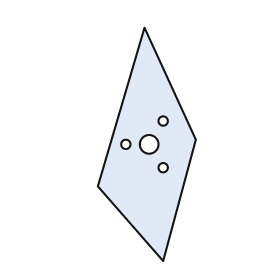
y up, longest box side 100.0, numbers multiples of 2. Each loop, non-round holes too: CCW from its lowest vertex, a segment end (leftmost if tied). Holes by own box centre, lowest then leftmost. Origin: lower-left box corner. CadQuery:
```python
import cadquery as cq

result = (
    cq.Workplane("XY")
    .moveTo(28.0, 0.0)
    .lineTo(42.0, 52.0)
    .lineTo(20.0, 100.0)
    .lineTo(0.0, 32.0)
    .close()
    .moveTo(28.0, 40.0)
    .circle(2.0)
    .moveTo(12.0, 50.0)
    .circle(2.0)
    .moveTo(22.0, 50.0)
    .circle(4.0)
    .moveTo(28.0, 60.0)
    .circle(2.0)
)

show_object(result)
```